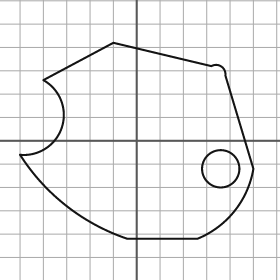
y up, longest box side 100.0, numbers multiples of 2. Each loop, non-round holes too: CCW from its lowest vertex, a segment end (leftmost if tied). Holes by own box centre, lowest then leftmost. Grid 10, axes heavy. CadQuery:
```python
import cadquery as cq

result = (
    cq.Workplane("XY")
    .moveTo(-4.0, -42.0)
    .lineTo(26.0, -42.0)
    .threePointArc((42.0, -30.0), (50.0, -12.0))
    .lineTo(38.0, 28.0)
    .threePointArc((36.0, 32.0), (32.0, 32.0))
    .lineTo(-10.0, 42.0)
    .lineTo(-40.0, 26.0)
    .threePointArc((-32.0, 6.0), (-50.0, -6.0))
    .threePointArc((-30.0, -28.0), (-4.0, -42.0))
    .close()
    .moveTo(36.0, -12.0)
    .circle(8.0)
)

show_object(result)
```